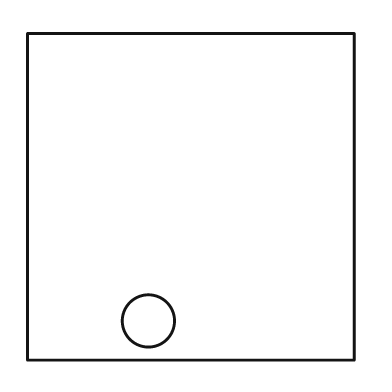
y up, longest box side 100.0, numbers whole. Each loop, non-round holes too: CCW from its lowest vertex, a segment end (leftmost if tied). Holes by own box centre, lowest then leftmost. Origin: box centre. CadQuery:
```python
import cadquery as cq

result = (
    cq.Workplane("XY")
    .moveTo(-50.0, -50.0)
    .lineTo(50.0, -50.0)
    .lineTo(50.0, 50.0)
    .lineTo(-50.0, 50.0)
    .close()
    .moveTo(-13.0, -38.0)
    .circle(8.0)
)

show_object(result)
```